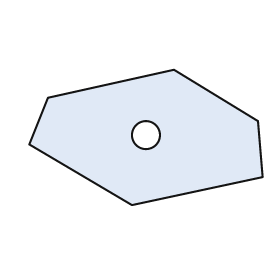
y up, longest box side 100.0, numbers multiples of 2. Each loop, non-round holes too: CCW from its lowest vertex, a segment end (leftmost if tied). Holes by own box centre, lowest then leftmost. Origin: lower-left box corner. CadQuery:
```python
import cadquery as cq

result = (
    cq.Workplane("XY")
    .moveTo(44.0, 0.0)
    .lineTo(100.0, 12.0)
    .lineTo(98.0, 36.0)
    .lineTo(62.0, 58.0)
    .lineTo(8.0, 46.0)
    .lineTo(0.0, 26.0)
    .close()
    .moveTo(50.0, 30.0)
    .circle(6.0)
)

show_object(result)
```